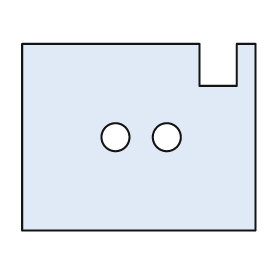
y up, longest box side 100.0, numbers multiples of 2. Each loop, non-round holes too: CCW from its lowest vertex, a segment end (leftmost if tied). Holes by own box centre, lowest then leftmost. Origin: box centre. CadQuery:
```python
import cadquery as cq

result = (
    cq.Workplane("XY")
    .moveTo(-50.0, -40.0)
    .lineTo(50.0, -40.0)
    .lineTo(50.0, 40.0)
    .lineTo(42.0, 40.0)
    .lineTo(42.0, 22.0)
    .lineTo(26.0, 22.0)
    .lineTo(26.0, 40.0)
    .lineTo(-50.0, 40.0)
    .close()
    .moveTo(-10.0, 0.0)
    .circle(6.0)
    .moveTo(12.0, 0.0)
    .circle(6.0)
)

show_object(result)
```